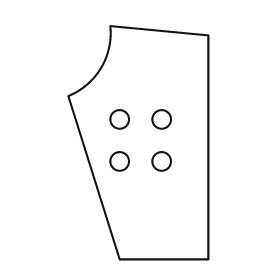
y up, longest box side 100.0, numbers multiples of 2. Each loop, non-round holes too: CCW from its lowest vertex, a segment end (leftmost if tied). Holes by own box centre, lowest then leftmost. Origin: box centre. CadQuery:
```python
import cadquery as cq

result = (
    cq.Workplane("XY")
    .moveTo(-8.0, -50.0)
    .lineTo(30.0, -50.0)
    .lineTo(30.0, 46.0)
    .lineTo(-12.0, 50.0)
    .threePointArc((-16.0, 32.0), (-30.0, 20.0))
    .close()
    .moveTo(-8.0, -8.0)
    .circle(4.0)
    .moveTo(10.0, -8.0)
    .circle(4.0)
    .moveTo(-8.0, 10.0)
    .circle(4.0)
    .moveTo(10.0, 10.0)
    .circle(4.0)
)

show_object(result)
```